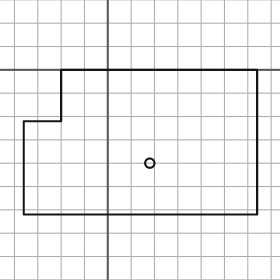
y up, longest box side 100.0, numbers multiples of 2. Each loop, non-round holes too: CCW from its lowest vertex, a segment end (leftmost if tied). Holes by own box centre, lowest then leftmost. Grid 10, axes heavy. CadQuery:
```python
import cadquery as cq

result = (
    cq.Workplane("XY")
    .moveTo(-36.0, -62.0)
    .lineTo(64.0, -62.0)
    .lineTo(64.0, 0.0)
    .lineTo(-20.0, 0.0)
    .lineTo(-20.0, -22.0)
    .lineTo(-36.0, -22.0)
    .close()
    .moveTo(18.0, -40.0)
    .circle(2.0)
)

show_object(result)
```